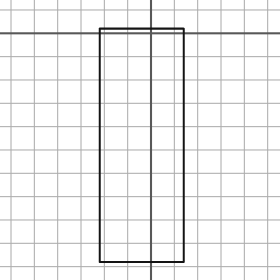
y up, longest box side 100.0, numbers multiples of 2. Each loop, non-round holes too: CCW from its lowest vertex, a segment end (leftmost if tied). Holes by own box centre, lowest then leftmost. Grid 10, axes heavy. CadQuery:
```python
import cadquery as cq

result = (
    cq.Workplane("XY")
    .moveTo(-22.0, -98.0)
    .lineTo(14.0, -98.0)
    .lineTo(14.0, 2.0)
    .lineTo(-22.0, 2.0)
    .close()
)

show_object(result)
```